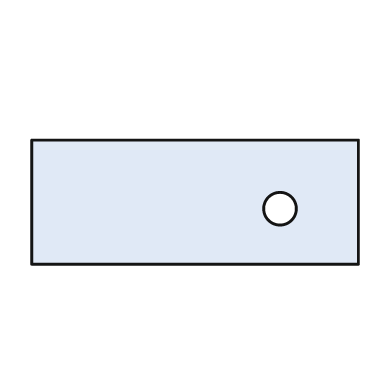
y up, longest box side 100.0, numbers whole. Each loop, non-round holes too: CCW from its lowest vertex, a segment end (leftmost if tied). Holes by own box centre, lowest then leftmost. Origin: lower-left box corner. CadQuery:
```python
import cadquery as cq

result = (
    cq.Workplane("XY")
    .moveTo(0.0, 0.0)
    .lineTo(100.0, 0.0)
    .lineTo(100.0, 38.0)
    .lineTo(0.0, 38.0)
    .close()
    .moveTo(76.0, 17.0)
    .circle(5.0)
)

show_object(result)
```